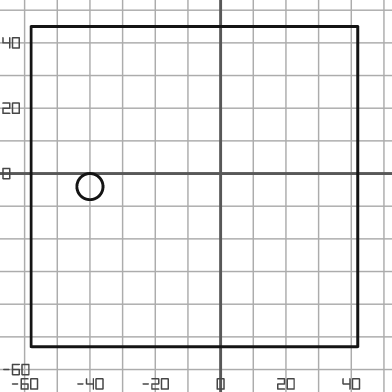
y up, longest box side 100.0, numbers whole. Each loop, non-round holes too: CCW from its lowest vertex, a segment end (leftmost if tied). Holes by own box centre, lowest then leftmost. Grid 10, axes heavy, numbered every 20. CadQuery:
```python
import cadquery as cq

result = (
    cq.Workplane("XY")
    .moveTo(-58.0, -53.0)
    .lineTo(42.0, -53.0)
    .lineTo(42.0, 45.0)
    .lineTo(-58.0, 45.0)
    .close()
    .moveTo(-40.0, -4.0)
    .circle(4.0)
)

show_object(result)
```